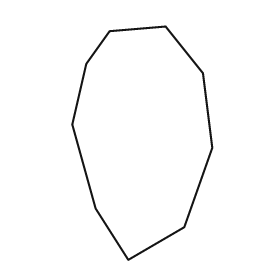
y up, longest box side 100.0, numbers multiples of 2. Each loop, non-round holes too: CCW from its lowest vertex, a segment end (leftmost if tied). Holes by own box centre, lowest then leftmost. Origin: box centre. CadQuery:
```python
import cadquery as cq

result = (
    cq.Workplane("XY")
    .moveTo(-6.0, -50.0)
    .lineTo(18.0, -36.0)
    .lineTo(30.0, -2.0)
    .lineTo(26.0, 30.0)
    .lineTo(10.0, 50.0)
    .lineTo(-14.0, 48.0)
    .lineTo(-24.0, 34.0)
    .lineTo(-30.0, 8.0)
    .lineTo(-20.0, -28.0)
    .close()
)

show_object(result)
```